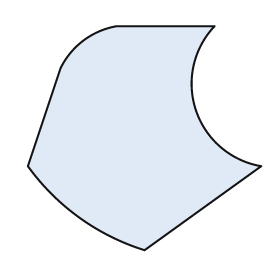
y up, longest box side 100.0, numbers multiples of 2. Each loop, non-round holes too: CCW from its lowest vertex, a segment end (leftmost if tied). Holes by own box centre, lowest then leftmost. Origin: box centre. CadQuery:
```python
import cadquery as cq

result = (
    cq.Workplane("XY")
    .moveTo(0.0, -48.0)
    .lineTo(50.0, -12.0)
    .threePointArc((22.0, 12.0), (30.0, 48.0))
    .lineTo(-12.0, 48.0)
    .threePointArc((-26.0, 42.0), (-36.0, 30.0))
    .lineTo(-50.0, -12.0)
    .threePointArc((-28.0, -34.0), (0.0, -48.0))
    .close()
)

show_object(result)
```